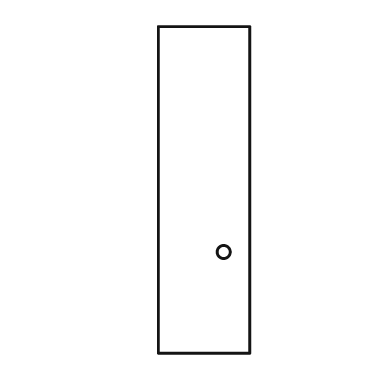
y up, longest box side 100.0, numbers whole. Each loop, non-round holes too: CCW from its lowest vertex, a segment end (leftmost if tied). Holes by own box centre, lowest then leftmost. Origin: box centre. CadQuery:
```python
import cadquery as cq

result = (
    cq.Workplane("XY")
    .moveTo(-14.0, -50.0)
    .lineTo(14.0, -50.0)
    .lineTo(14.0, 50.0)
    .lineTo(-14.0, 50.0)
    .close()
    .moveTo(6.0, -19.0)
    .circle(2.0)
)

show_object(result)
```